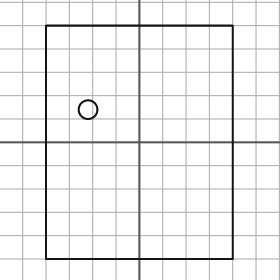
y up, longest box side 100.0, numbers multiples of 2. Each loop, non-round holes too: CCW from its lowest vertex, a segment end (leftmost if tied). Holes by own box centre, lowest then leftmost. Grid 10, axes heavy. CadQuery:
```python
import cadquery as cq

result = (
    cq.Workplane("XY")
    .moveTo(-40.0, -50.0)
    .lineTo(40.0, -50.0)
    .lineTo(40.0, 50.0)
    .lineTo(-40.0, 50.0)
    .close()
    .moveTo(-22.0, 14.0)
    .circle(4.0)
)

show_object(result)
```